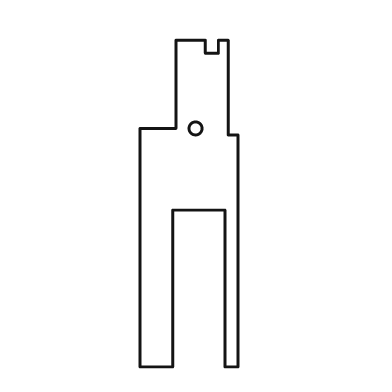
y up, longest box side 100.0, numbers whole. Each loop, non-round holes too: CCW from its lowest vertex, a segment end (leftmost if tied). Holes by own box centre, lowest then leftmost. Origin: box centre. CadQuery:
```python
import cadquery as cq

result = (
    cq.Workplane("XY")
    .moveTo(-15.0, -50.0)
    .lineTo(-5.0, -50.0)
    .lineTo(-5.0, -2.0)
    .lineTo(11.0, -2.0)
    .lineTo(11.0, -50.0)
    .lineTo(15.0, -50.0)
    .lineTo(15.0, 21.0)
    .lineTo(12.0, 21.0)
    .lineTo(12.0, 50.0)
    .lineTo(9.0, 50.0)
    .lineTo(9.0, 46.0)
    .lineTo(5.0, 46.0)
    .lineTo(5.0, 50.0)
    .lineTo(-4.0, 50.0)
    .lineTo(-4.0, 23.0)
    .lineTo(-15.0, 23.0)
    .close()
    .moveTo(2.0, 23.0)
    .circle(2.0)
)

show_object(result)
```